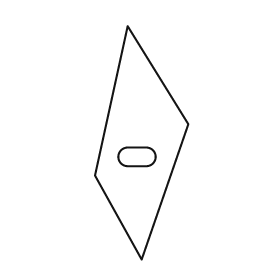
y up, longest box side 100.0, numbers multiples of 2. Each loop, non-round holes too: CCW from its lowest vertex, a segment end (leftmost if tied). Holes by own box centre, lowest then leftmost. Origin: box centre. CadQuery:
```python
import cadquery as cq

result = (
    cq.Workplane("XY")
    .moveTo(0.0, -50.0)
    .lineTo(20.0, 8.0)
    .lineTo(-6.0, 50.0)
    .lineTo(-20.0, -14.0)
    .close()
    .moveTo(-6.0, -10.0)
    .lineTo(2.0, -10.0)
    .threePointArc((6.0, -6.0), (2.0, -2.0))
    .lineTo(-6.0, -2.0)
    .threePointArc((-10.0, -6.0), (-6.0, -10.0))
    .close()
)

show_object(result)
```